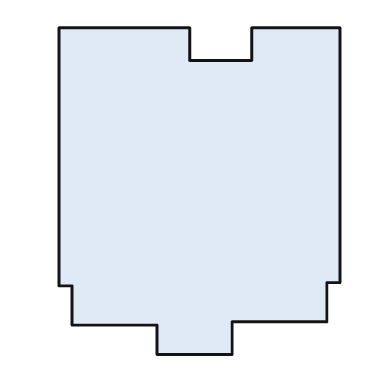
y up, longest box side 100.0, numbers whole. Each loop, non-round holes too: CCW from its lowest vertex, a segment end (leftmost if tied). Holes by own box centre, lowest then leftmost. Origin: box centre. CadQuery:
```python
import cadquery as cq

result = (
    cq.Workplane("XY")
    .moveTo(-13.0, -50.0)
    .lineTo(10.0, -50.0)
    .lineTo(10.0, -40.0)
    .lineTo(39.0, -40.0)
    .lineTo(39.0, -28.0)
    .lineTo(43.0, -28.0)
    .lineTo(43.0, 50.0)
    .lineTo(16.0, 50.0)
    .lineTo(16.0, 40.0)
    .lineTo(-3.0, 40.0)
    .lineTo(-3.0, 50.0)
    .lineTo(-43.0, 50.0)
    .lineTo(-43.0, -29.0)
    .lineTo(-39.0, -29.0)
    .lineTo(-39.0, -41.0)
    .lineTo(-13.0, -41.0)
    .close()
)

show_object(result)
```